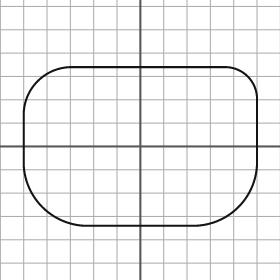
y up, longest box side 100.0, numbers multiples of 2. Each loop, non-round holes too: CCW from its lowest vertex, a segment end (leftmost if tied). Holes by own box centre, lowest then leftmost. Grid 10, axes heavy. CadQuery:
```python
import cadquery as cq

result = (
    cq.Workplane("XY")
    .moveTo(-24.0, -34.0)
    .lineTo(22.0, -34.0)
    .threePointArc((42.0, -26.0), (50.0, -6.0))
    .lineTo(50.0, 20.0)
    .threePointArc((46.0, 30.0), (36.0, 34.0))
    .lineTo(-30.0, 34.0)
    .threePointArc((-44.0, 28.0), (-50.0, 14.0))
    .lineTo(-50.0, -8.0)
    .threePointArc((-42.0, -26.0), (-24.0, -34.0))
    .close()
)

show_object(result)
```